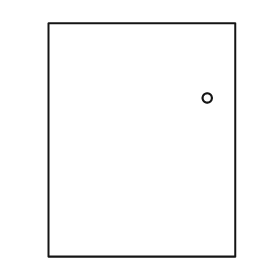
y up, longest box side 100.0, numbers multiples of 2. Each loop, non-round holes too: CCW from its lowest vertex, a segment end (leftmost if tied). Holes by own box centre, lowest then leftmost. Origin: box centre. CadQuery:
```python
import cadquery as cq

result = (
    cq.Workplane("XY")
    .moveTo(-40.0, -50.0)
    .lineTo(40.0, -50.0)
    .lineTo(40.0, 50.0)
    .lineTo(-40.0, 50.0)
    .close()
    .moveTo(28.0, 18.0)
    .circle(2.0)
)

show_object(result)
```